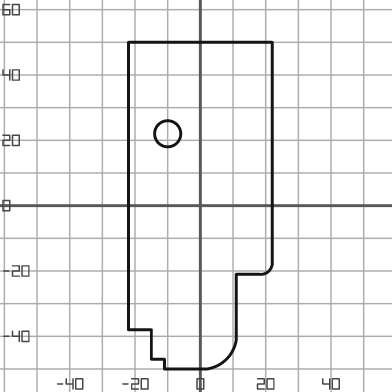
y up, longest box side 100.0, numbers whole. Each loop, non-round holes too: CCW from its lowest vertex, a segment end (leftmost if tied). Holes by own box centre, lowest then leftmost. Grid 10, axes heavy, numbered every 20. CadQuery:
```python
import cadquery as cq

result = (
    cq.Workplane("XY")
    .moveTo(-11.0, -50.0)
    .lineTo(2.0, -50.0)
    .threePointArc((8.0, -47.0), (11.0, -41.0))
    .lineTo(11.0, -21.0)
    .lineTo(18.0, -21.0)
    .threePointArc((21.0, -20.0), (22.0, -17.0))
    .lineTo(22.0, 50.0)
    .lineTo(-22.0, 50.0)
    .lineTo(-22.0, -38.0)
    .lineTo(-15.0, -38.0)
    .lineTo(-15.0, -47.0)
    .lineTo(-11.0, -47.0)
    .close()
    .moveTo(-10.0, 22.0)
    .circle(4.0)
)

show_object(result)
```